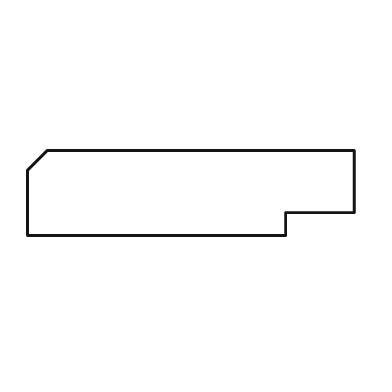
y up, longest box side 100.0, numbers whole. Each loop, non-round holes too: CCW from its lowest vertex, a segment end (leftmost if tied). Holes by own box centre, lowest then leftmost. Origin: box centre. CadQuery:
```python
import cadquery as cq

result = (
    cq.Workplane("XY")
    .moveTo(-50.0, -13.0)
    .lineTo(29.0, -13.0)
    .lineTo(29.0, -6.0)
    .lineTo(50.0, -6.0)
    .lineTo(50.0, 13.0)
    .lineTo(-44.0, 13.0)
    .lineTo(-50.0, 7.0)
    .close()
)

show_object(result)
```